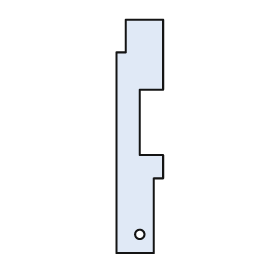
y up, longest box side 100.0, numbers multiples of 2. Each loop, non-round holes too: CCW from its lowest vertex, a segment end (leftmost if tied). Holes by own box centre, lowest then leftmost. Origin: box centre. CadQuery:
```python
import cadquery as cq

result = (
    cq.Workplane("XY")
    .moveTo(-10.0, -50.0)
    .lineTo(6.0, -50.0)
    .lineTo(6.0, -18.0)
    .lineTo(10.0, -18.0)
    .lineTo(10.0, -8.0)
    .lineTo(0.0, -8.0)
    .lineTo(0.0, 20.0)
    .lineTo(10.0, 20.0)
    .lineTo(10.0, 50.0)
    .lineTo(-6.0, 50.0)
    .lineTo(-6.0, 36.0)
    .lineTo(-10.0, 36.0)
    .close()
    .moveTo(0.0, -42.0)
    .circle(2.0)
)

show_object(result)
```